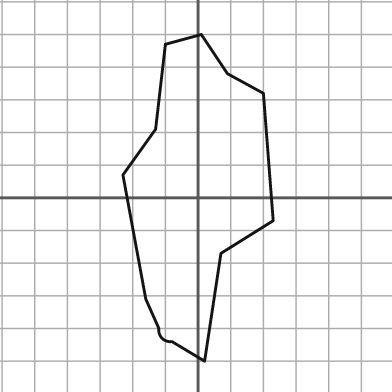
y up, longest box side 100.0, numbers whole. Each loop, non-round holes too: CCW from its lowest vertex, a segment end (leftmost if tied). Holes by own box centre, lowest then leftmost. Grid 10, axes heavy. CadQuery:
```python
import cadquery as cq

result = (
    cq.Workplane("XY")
    .moveTo(2.0, -50.0)
    .lineTo(7.0, -17.0)
    .lineTo(23.0, -7.0)
    .lineTo(20.0, 32.0)
    .lineTo(9.0, 38.0)
    .lineTo(1.0, 50.0)
    .lineTo(-10.0, 47.0)
    .lineTo(-13.0, 21.0)
    .lineTo(-23.0, 7.0)
    .lineTo(-16.0, -31.0)
    .lineTo(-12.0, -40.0)
    .threePointArc((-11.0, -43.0), (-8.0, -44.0))
    .close()
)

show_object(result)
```